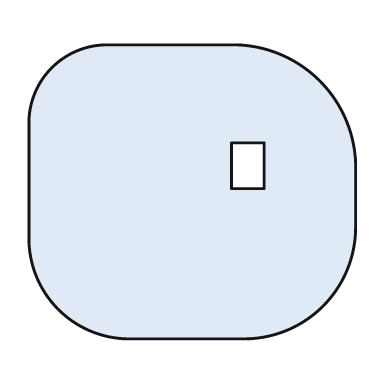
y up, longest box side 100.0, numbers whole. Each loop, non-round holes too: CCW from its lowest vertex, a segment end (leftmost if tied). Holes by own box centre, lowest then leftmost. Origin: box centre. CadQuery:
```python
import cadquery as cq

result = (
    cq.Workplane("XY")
    .moveTo(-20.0, -45.0)
    .lineTo(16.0, -45.0)
    .threePointArc((40.0, -35.0), (50.0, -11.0))
    .lineTo(50.0, 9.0)
    .threePointArc((39.0, 34.0), (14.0, 45.0))
    .lineTo(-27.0, 45.0)
    .threePointArc((-43.0, 38.0), (-50.0, 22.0))
    .lineTo(-50.0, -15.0)
    .threePointArc((-41.0, -36.0), (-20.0, -45.0))
    .close()
    .moveTo(12.0, 1.0)
    .lineTo(22.0, 1.0)
    .lineTo(22.0, 15.0)
    .lineTo(12.0, 15.0)
    .close()
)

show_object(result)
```